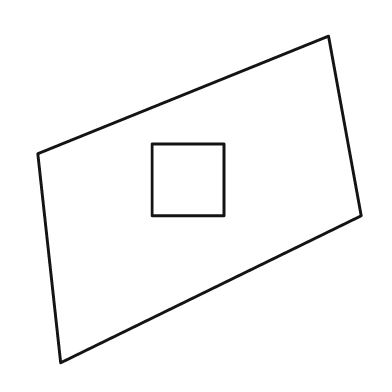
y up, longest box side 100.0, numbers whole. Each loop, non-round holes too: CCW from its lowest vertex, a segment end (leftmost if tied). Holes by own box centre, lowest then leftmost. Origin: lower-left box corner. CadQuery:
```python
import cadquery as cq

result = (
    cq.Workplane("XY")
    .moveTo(7.0, 0.0)
    .lineTo(99.0, 45.0)
    .lineTo(89.0, 100.0)
    .lineTo(0.0, 64.0)
    .close()
    .moveTo(35.0, 45.0)
    .lineTo(57.0, 45.0)
    .lineTo(57.0, 67.0)
    .lineTo(35.0, 67.0)
    .close()
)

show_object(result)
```